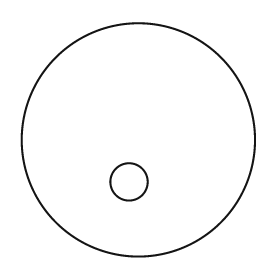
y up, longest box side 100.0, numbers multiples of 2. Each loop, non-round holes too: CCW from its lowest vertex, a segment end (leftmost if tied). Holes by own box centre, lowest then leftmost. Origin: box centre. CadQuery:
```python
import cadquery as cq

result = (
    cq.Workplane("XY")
    .moveTo(0.0, 0.0)
    .circle(50.0)
    .moveTo(-4.0, -18.0)
    .circle(8.0)
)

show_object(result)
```